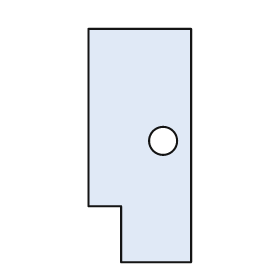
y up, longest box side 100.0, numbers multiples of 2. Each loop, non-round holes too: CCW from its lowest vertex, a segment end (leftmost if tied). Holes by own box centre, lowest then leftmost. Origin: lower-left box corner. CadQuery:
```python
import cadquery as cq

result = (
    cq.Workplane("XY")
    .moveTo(14.0, 0.0)
    .lineTo(44.0, 0.0)
    .lineTo(44.0, 100.0)
    .lineTo(0.0, 100.0)
    .lineTo(0.0, 24.0)
    .lineTo(14.0, 24.0)
    .close()
    .moveTo(32.0, 52.0)
    .circle(6.0)
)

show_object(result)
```